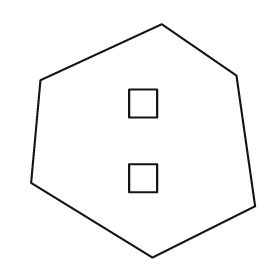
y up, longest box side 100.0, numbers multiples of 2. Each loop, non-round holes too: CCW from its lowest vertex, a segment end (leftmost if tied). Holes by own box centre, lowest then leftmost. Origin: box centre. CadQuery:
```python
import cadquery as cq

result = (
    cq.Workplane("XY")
    .moveTo(4.0, -50.0)
    .lineTo(48.0, -28.0)
    .lineTo(40.0, 28.0)
    .lineTo(8.0, 50.0)
    .lineTo(-44.0, 26.0)
    .lineTo(-48.0, -18.0)
    .close()
    .moveTo(-6.0, -22.0)
    .lineTo(6.0, -22.0)
    .lineTo(6.0, -10.0)
    .lineTo(-6.0, -10.0)
    .close()
    .moveTo(-6.0, 10.0)
    .lineTo(6.0, 10.0)
    .lineTo(6.0, 22.0)
    .lineTo(-6.0, 22.0)
    .close()
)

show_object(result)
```